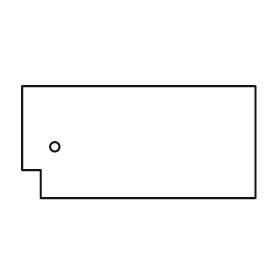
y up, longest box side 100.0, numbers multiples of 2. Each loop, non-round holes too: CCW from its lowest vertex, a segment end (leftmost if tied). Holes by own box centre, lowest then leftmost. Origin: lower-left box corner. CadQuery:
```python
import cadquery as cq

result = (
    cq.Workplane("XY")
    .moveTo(8.0, 0.0)
    .lineTo(100.0, 0.0)
    .lineTo(100.0, 48.0)
    .lineTo(0.0, 48.0)
    .lineTo(0.0, 12.0)
    .lineTo(8.0, 12.0)
    .close()
    .moveTo(14.0, 22.0)
    .circle(2.0)
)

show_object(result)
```